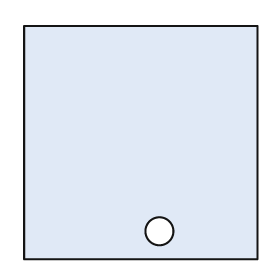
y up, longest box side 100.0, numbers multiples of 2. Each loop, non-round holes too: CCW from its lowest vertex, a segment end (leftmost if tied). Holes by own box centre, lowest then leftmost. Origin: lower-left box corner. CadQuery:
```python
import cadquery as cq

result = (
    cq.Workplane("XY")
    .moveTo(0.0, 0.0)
    .lineTo(100.0, 0.0)
    .lineTo(100.0, 100.0)
    .lineTo(0.0, 100.0)
    .close()
    .moveTo(58.0, 12.0)
    .circle(6.0)
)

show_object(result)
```